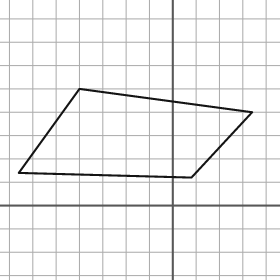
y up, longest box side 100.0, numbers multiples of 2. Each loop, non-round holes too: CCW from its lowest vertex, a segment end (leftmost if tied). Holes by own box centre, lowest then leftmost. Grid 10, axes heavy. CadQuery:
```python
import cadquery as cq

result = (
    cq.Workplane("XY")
    .moveTo(8.0, 12.0)
    .lineTo(34.0, 40.0)
    .lineTo(-40.0, 50.0)
    .lineTo(-66.0, 14.0)
    .close()
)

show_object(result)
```